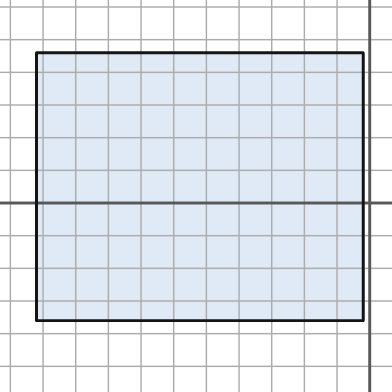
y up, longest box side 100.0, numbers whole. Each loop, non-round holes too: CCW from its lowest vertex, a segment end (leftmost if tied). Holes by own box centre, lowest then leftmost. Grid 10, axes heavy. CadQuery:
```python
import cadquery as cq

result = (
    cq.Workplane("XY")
    .moveTo(-102.0, -36.0)
    .lineTo(-2.0, -36.0)
    .lineTo(-2.0, 46.0)
    .lineTo(-102.0, 46.0)
    .close()
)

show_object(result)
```